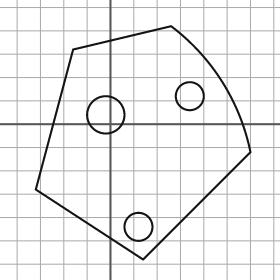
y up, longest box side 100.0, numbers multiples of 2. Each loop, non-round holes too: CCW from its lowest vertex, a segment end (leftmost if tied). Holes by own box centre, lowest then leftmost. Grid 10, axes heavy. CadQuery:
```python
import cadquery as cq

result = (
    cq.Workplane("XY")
    .moveTo(14.0, -58.0)
    .lineTo(60.0, -12.0)
    .threePointArc((48.0, 18.0), (26.0, 42.0))
    .lineTo(-16.0, 32.0)
    .lineTo(-32.0, -28.0)
    .close()
    .moveTo(12.0, -44.0)
    .circle(6.0)
    .moveTo(-2.0, 4.0)
    .circle(8.0)
    .moveTo(34.0, 12.0)
    .circle(6.0)
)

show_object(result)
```